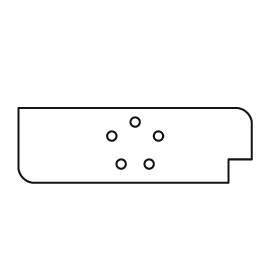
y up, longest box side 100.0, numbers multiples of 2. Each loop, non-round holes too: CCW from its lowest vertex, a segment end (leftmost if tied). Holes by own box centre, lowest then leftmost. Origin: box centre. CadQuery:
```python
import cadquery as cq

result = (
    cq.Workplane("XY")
    .moveTo(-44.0, -16.0)
    .lineTo(40.0, -16.0)
    .lineTo(40.0, -6.0)
    .lineTo(50.0, -6.0)
    .lineTo(50.0, 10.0)
    .threePointArc((48.0, 14.0), (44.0, 16.0))
    .lineTo(-50.0, 16.0)
    .lineTo(-50.0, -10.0)
    .threePointArc((-48.0, -14.0), (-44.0, -16.0))
    .close()
    .moveTo(-6.0, -8.0)
    .circle(2.0)
    .moveTo(6.0, -8.0)
    .circle(2.0)
    .moveTo(-10.0, 4.0)
    .circle(2.0)
    .moveTo(10.0, 4.0)
    .circle(2.0)
    .moveTo(0.0, 10.0)
    .circle(2.0)
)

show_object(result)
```